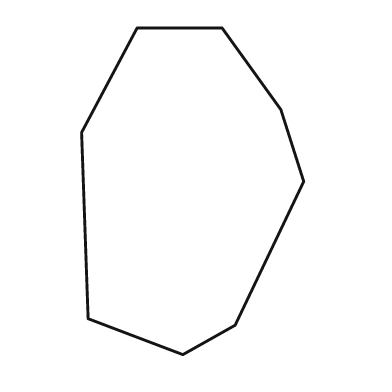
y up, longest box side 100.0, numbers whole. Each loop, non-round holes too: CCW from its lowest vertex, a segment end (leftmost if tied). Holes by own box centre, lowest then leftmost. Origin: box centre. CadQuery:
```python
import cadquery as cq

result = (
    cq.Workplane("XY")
    .moveTo(-3.0, -50.0)
    .lineTo(13.0, -41.0)
    .lineTo(34.0, 3.0)
    .lineTo(27.0, 25.0)
    .lineTo(9.0, 50.0)
    .lineTo(-17.0, 50.0)
    .lineTo(-34.0, 18.0)
    .lineTo(-32.0, -39.0)
    .close()
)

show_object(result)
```